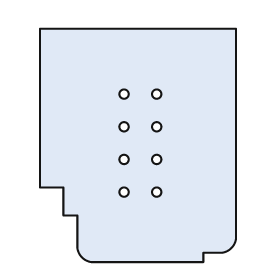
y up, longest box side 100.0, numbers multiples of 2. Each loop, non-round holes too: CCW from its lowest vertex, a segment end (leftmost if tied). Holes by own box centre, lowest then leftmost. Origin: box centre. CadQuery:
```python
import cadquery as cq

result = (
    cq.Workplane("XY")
    .moveTo(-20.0, -50.0)
    .lineTo(28.0, -50.0)
    .lineTo(28.0, -46.0)
    .lineTo(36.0, -46.0)
    .threePointArc((40.0, -44.0), (42.0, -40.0))
    .lineTo(42.0, 50.0)
    .lineTo(-42.0, 50.0)
    .lineTo(-42.0, -18.0)
    .lineTo(-32.0, -18.0)
    .lineTo(-32.0, -30.0)
    .lineTo(-26.0, -30.0)
    .lineTo(-26.0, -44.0)
    .threePointArc((-24.0, -48.0), (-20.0, -50.0))
    .close()
    .moveTo(-6.0, -20.0)
    .circle(2.0)
    .moveTo(8.0, -20.0)
    .circle(2.0)
    .moveTo(-6.0, -6.0)
    .circle(2.0)
    .moveTo(8.0, -6.0)
    .circle(2.0)
    .moveTo(-6.0, 8.0)
    .circle(2.0)
    .moveTo(8.0, 8.0)
    .circle(2.0)
    .moveTo(-6.0, 22.0)
    .circle(2.0)
    .moveTo(8.0, 22.0)
    .circle(2.0)
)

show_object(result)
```